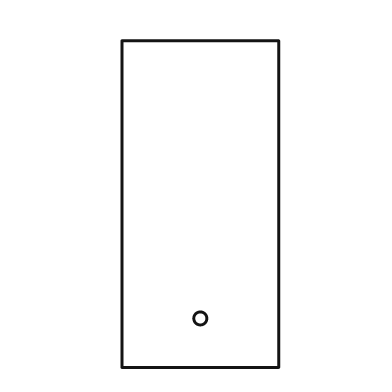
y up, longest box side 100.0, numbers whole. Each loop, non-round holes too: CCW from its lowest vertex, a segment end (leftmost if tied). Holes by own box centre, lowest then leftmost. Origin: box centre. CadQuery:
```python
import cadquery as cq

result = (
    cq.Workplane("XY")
    .moveTo(-24.0, -50.0)
    .lineTo(24.0, -50.0)
    .lineTo(24.0, 50.0)
    .lineTo(-24.0, 50.0)
    .close()
    .moveTo(0.0, -35.0)
    .circle(2.0)
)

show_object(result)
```